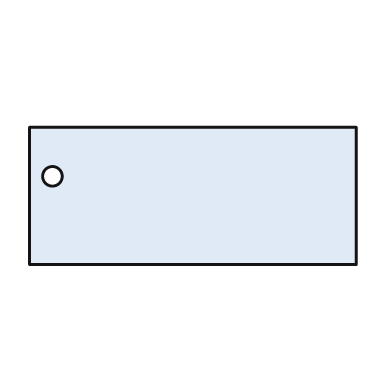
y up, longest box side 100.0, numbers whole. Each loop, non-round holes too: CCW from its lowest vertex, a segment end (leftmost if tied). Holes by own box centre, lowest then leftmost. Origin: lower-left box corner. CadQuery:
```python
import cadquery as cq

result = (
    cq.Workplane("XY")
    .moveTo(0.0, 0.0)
    .lineTo(100.0, 0.0)
    .lineTo(100.0, 42.0)
    .lineTo(0.0, 42.0)
    .close()
    .moveTo(7.0, 27.0)
    .circle(3.0)
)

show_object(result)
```